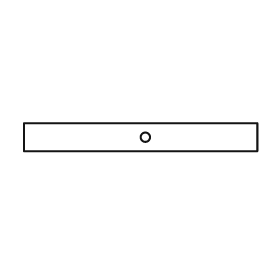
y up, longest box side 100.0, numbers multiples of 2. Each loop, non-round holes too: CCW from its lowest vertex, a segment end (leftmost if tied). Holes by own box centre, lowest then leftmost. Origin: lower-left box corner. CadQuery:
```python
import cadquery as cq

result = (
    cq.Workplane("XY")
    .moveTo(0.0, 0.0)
    .lineTo(100.0, 0.0)
    .lineTo(100.0, 12.0)
    .lineTo(0.0, 12.0)
    .close()
    .moveTo(52.0, 6.0)
    .circle(2.0)
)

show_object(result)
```